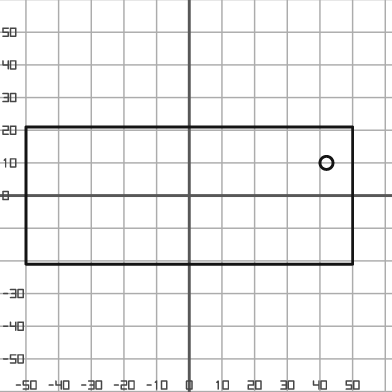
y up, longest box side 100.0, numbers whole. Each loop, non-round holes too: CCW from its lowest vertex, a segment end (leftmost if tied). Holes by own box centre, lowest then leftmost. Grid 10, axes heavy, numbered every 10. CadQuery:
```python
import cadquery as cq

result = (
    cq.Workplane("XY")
    .moveTo(-50.0, -21.0)
    .lineTo(50.0, -21.0)
    .lineTo(50.0, 21.0)
    .lineTo(-50.0, 21.0)
    .close()
    .moveTo(42.0, 10.0)
    .circle(2.0)
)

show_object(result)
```